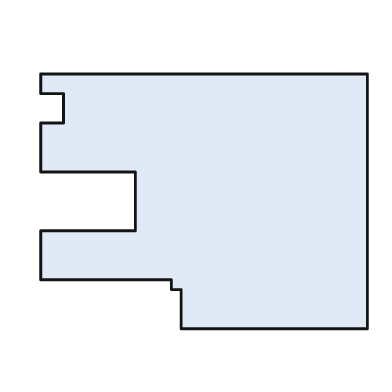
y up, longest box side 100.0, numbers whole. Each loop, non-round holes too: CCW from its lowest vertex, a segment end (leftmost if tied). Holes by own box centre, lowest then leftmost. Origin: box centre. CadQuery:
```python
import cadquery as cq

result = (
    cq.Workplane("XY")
    .moveTo(-7.0, -39.0)
    .lineTo(50.0, -39.0)
    .lineTo(50.0, 39.0)
    .lineTo(-50.0, 39.0)
    .lineTo(-50.0, 33.0)
    .lineTo(-43.0, 33.0)
    .lineTo(-43.0, 24.0)
    .lineTo(-50.0, 24.0)
    .lineTo(-50.0, 9.0)
    .lineTo(-21.0, 9.0)
    .lineTo(-21.0, -9.0)
    .lineTo(-50.0, -9.0)
    .lineTo(-50.0, -24.0)
    .lineTo(-10.0, -24.0)
    .lineTo(-10.0, -27.0)
    .lineTo(-7.0, -27.0)
    .close()
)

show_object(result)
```